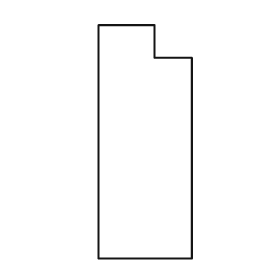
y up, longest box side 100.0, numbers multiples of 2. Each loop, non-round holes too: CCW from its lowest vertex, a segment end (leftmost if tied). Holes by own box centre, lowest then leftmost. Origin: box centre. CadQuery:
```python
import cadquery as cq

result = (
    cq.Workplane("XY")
    .moveTo(-20.0, -50.0)
    .lineTo(20.0, -50.0)
    .lineTo(20.0, 36.0)
    .lineTo(4.0, 36.0)
    .lineTo(4.0, 50.0)
    .lineTo(-20.0, 50.0)
    .close()
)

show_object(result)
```